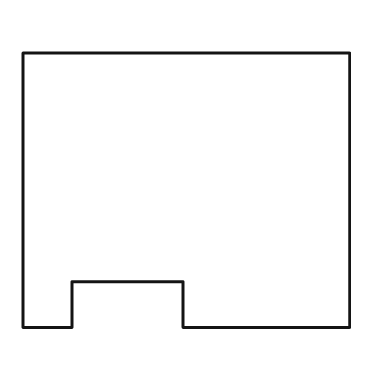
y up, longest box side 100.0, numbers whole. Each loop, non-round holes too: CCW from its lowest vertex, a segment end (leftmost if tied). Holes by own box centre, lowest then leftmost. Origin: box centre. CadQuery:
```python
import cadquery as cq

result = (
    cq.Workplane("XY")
    .moveTo(-50.0, -42.0)
    .lineTo(-35.0, -42.0)
    .lineTo(-35.0, -28.0)
    .lineTo(-1.0, -28.0)
    .lineTo(-1.0, -42.0)
    .lineTo(50.0, -42.0)
    .lineTo(50.0, 42.0)
    .lineTo(-50.0, 42.0)
    .close()
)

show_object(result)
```